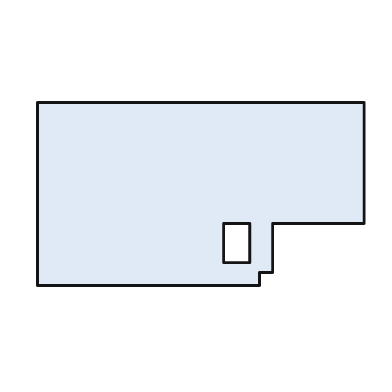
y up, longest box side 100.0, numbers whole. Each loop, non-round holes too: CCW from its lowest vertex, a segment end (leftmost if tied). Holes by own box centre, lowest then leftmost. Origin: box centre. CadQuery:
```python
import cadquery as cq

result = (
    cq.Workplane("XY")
    .moveTo(-50.0, -28.0)
    .lineTo(18.0, -28.0)
    .lineTo(18.0, -24.0)
    .lineTo(22.0, -24.0)
    .lineTo(22.0, -9.0)
    .lineTo(50.0, -9.0)
    .lineTo(50.0, 28.0)
    .lineTo(-50.0, 28.0)
    .close()
    .moveTo(7.0, -21.0)
    .lineTo(15.0, -21.0)
    .lineTo(15.0, -9.0)
    .lineTo(7.0, -9.0)
    .close()
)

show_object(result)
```